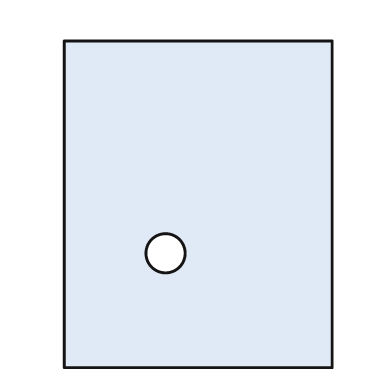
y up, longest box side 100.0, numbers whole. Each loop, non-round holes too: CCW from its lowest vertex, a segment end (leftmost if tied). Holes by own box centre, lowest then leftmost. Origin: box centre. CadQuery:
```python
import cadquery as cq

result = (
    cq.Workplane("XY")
    .moveTo(-41.0, -50.0)
    .lineTo(41.0, -50.0)
    .lineTo(41.0, 50.0)
    .lineTo(-41.0, 50.0)
    .close()
    .moveTo(-10.0, -15.0)
    .circle(6.0)
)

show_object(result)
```